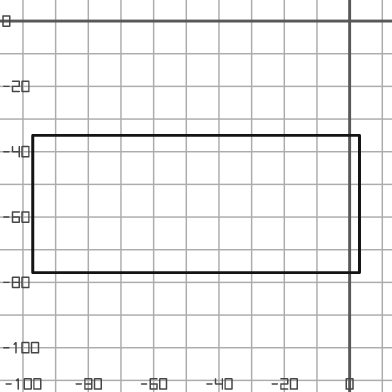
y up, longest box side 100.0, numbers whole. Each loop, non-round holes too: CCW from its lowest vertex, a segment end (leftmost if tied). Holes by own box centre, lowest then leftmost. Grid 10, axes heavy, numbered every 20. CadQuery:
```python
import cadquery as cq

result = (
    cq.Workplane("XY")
    .moveTo(-97.0, -77.0)
    .lineTo(3.0, -77.0)
    .lineTo(3.0, -35.0)
    .lineTo(-97.0, -35.0)
    .close()
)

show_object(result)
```